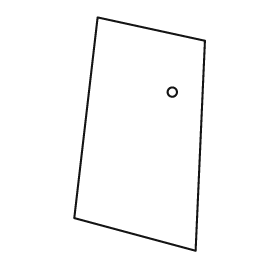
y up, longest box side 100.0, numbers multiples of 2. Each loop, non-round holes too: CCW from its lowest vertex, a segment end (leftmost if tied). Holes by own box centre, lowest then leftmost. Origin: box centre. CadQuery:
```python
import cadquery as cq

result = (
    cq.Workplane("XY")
    .moveTo(24.0, -50.0)
    .lineTo(28.0, 40.0)
    .lineTo(-18.0, 50.0)
    .lineTo(-28.0, -36.0)
    .close()
    .moveTo(14.0, 18.0)
    .circle(2.0)
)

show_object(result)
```